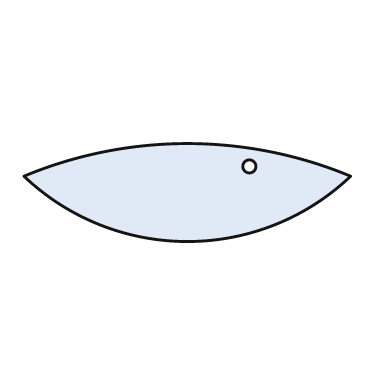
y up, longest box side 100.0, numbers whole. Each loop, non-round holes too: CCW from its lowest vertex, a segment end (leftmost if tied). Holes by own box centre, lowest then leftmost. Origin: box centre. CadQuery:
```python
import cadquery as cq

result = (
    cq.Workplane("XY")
    .moveTo(-50.0, 5.0)
    .threePointArc((0.0, -15.0), (50.0, 5.0))
    .threePointArc((0.0, 15.0), (-50.0, 5.0))
    .close()
    .moveTo(19.0, 8.0)
    .circle(2.0)
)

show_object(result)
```